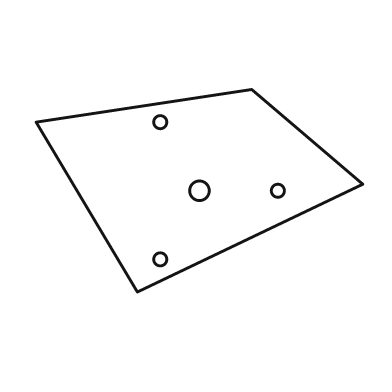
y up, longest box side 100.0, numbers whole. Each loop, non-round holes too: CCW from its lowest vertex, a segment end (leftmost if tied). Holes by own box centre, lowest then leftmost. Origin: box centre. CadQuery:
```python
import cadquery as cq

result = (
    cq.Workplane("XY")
    .moveTo(-19.0, -31.0)
    .lineTo(50.0, 2.0)
    .lineTo(16.0, 31.0)
    .lineTo(-50.0, 21.0)
    .close()
    .moveTo(-12.0, -21.0)
    .circle(2.0)
    .moveTo(0.0, 0.0)
    .circle(3.0)
    .moveTo(24.0, 0.0)
    .circle(2.0)
    .moveTo(-12.0, 21.0)
    .circle(2.0)
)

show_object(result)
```